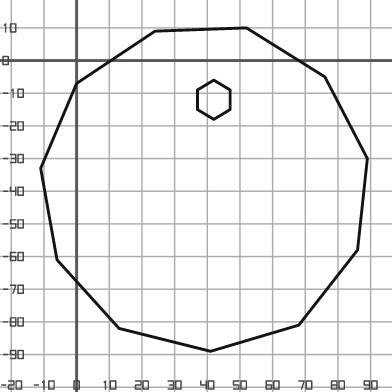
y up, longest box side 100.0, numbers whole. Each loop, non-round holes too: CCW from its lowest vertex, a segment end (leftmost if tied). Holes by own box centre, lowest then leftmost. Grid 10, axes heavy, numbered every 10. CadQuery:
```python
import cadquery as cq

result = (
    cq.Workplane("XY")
    .moveTo(41.0, -89.0)
    .lineTo(68.0, -81.0)
    .lineTo(86.0, -58.0)
    .lineTo(89.0, -30.0)
    .lineTo(76.0, -5.0)
    .lineTo(52.0, 10.0)
    .lineTo(24.0, 9.0)
    .lineTo(0.0, -7.0)
    .lineTo(-11.0, -33.0)
    .lineTo(-6.0, -61.0)
    .lineTo(13.0, -82.0)
    .close()
    .moveTo(42.0, -18.0)
    .lineTo(47.0, -15.0)
    .lineTo(47.0, -9.0)
    .lineTo(42.0, -6.0)
    .lineTo(37.0, -9.0)
    .lineTo(37.0, -15.0)
    .close()
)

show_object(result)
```